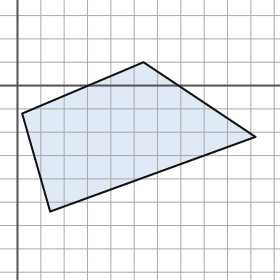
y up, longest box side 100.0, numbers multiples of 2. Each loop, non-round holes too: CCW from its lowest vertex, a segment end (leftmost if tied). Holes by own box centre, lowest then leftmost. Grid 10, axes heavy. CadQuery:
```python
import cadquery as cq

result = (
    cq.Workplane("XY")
    .moveTo(14.0, -54.0)
    .lineTo(102.0, -22.0)
    .lineTo(54.0, 10.0)
    .lineTo(2.0, -12.0)
    .close()
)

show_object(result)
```